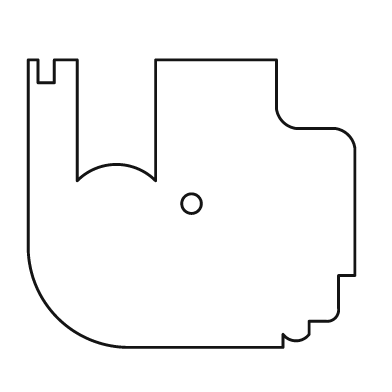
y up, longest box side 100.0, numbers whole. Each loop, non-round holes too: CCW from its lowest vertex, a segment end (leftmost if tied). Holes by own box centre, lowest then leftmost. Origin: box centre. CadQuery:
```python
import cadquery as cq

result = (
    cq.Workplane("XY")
    .moveTo(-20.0, -44.0)
    .lineTo(28.0, -44.0)
    .lineTo(28.0, -40.0)
    .threePointArc((32.0, -42.0), (36.0, -40.0))
    .lineTo(36.0, -36.0)
    .lineTo(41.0, -36.0)
    .threePointArc((44.0, -35.0), (45.0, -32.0))
    .lineTo(45.0, -22.0)
    .lineTo(50.0, -22.0)
    .lineTo(50.0, 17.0)
    .threePointArc((48.0, 21.0), (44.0, 23.0))
    .lineTo(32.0, 23.0)
    .threePointArc((28.0, 25.0), (26.0, 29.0))
    .lineTo(26.0, 44.0)
    .lineTo(-11.0, 44.0)
    .lineTo(-11.0, 7.0)
    .threePointArc((-23.0, 12.0), (-35.0, 7.0))
    .lineTo(-35.0, 44.0)
    .lineTo(-42.0, 44.0)
    .lineTo(-42.0, 37.0)
    .lineTo(-47.0, 37.0)
    .lineTo(-47.0, 44.0)
    .lineTo(-50.0, 44.0)
    .lineTo(-50.0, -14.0)
    .threePointArc((-41.0, -35.0), (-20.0, -44.0))
    .close()
    .moveTo(0.0, 0.0)
    .circle(3.0)
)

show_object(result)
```